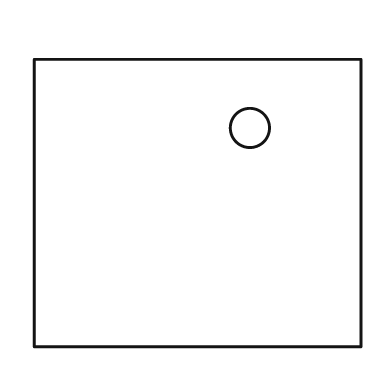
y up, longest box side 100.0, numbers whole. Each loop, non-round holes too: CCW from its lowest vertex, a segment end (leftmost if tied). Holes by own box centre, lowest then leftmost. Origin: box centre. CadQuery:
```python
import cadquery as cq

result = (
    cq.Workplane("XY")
    .moveTo(-50.0, -44.0)
    .lineTo(50.0, -44.0)
    .lineTo(50.0, 44.0)
    .lineTo(-50.0, 44.0)
    .close()
    .moveTo(16.0, 23.0)
    .circle(6.0)
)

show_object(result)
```